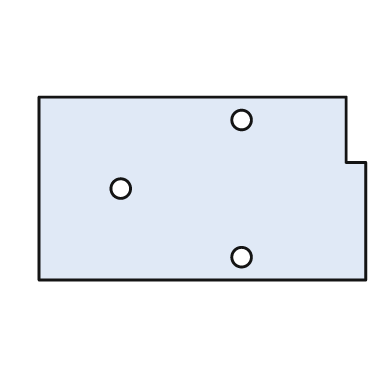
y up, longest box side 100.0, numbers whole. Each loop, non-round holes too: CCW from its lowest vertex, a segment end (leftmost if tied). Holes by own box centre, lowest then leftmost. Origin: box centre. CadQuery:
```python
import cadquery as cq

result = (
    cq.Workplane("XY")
    .moveTo(-50.0, -28.0)
    .lineTo(50.0, -28.0)
    .lineTo(50.0, 8.0)
    .lineTo(44.0, 8.0)
    .lineTo(44.0, 28.0)
    .lineTo(-50.0, 28.0)
    .close()
    .moveTo(12.0, -21.0)
    .circle(3.0)
    .moveTo(-25.0, 0.0)
    .circle(3.0)
    .moveTo(12.0, 21.0)
    .circle(3.0)
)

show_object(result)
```